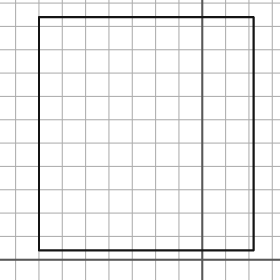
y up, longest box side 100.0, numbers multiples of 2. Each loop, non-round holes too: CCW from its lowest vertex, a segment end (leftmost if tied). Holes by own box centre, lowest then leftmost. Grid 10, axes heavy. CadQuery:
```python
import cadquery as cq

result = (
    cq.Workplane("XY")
    .moveTo(-70.0, 4.0)
    .lineTo(22.0, 4.0)
    .lineTo(22.0, 104.0)
    .lineTo(-70.0, 104.0)
    .close()
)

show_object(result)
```